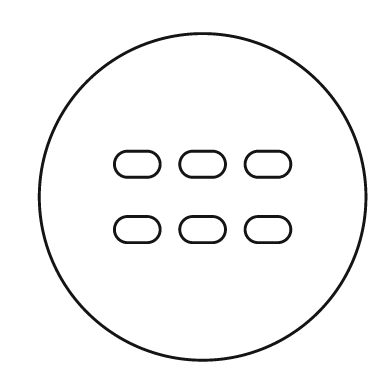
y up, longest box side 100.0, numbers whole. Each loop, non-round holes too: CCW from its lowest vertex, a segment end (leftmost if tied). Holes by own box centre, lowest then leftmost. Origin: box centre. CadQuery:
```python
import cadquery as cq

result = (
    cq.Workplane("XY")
    .moveTo(0.0, 0.0)
    .circle(50.0)
    .moveTo(-23.0, -14.0)
    .lineTo(-17.0, -14.0)
    .threePointArc((-13.0, -10.0), (-17.0, -6.0))
    .lineTo(-23.0, -6.0)
    .threePointArc((-27.0, -10.0), (-23.0, -14.0))
    .close()
    .moveTo(-3.0, -14.0)
    .lineTo(3.0, -14.0)
    .threePointArc((7.0, -10.0), (3.0, -6.0))
    .lineTo(-3.0, -6.0)
    .threePointArc((-7.0, -10.0), (-3.0, -14.0))
    .close()
    .moveTo(17.0, -14.0)
    .lineTo(23.0, -14.0)
    .threePointArc((27.0, -10.0), (23.0, -6.0))
    .lineTo(17.0, -6.0)
    .threePointArc((13.0, -10.0), (17.0, -14.0))
    .close()
    .moveTo(-23.0, 6.0)
    .lineTo(-17.0, 6.0)
    .threePointArc((-13.0, 10.0), (-17.0, 14.0))
    .lineTo(-23.0, 14.0)
    .threePointArc((-27.0, 10.0), (-23.0, 6.0))
    .close()
    .moveTo(-3.0, 6.0)
    .lineTo(3.0, 6.0)
    .threePointArc((7.0, 10.0), (3.0, 14.0))
    .lineTo(-3.0, 14.0)
    .threePointArc((-7.0, 10.0), (-3.0, 6.0))
    .close()
    .moveTo(17.0, 6.0)
    .lineTo(23.0, 6.0)
    .threePointArc((27.0, 10.0), (23.0, 14.0))
    .lineTo(17.0, 14.0)
    .threePointArc((13.0, 10.0), (17.0, 6.0))
    .close()
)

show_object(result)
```